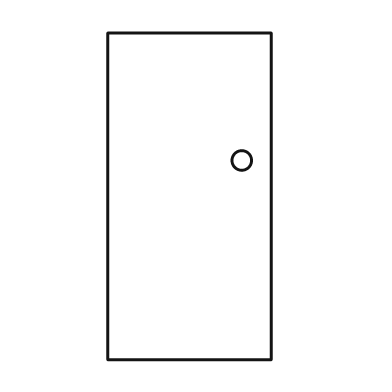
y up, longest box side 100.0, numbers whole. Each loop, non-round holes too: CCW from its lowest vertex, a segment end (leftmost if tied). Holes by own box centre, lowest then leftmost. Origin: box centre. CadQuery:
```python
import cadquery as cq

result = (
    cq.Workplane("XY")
    .moveTo(-25.0, -50.0)
    .lineTo(25.0, -50.0)
    .lineTo(25.0, 50.0)
    .lineTo(-25.0, 50.0)
    .close()
    .moveTo(16.0, 11.0)
    .circle(3.0)
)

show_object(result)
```